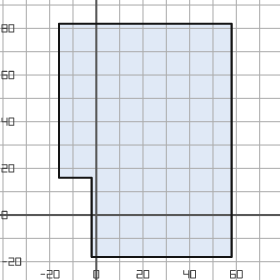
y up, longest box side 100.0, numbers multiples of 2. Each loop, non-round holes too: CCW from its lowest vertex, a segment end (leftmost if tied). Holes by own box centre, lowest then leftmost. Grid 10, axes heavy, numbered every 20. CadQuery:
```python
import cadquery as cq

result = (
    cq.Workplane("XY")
    .moveTo(-2.0, -18.0)
    .lineTo(58.0, -18.0)
    .lineTo(58.0, 82.0)
    .lineTo(-16.0, 82.0)
    .lineTo(-16.0, 16.0)
    .lineTo(-2.0, 16.0)
    .close()
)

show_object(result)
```